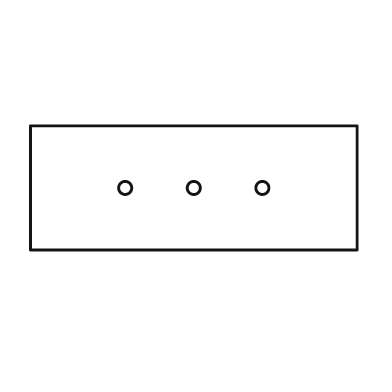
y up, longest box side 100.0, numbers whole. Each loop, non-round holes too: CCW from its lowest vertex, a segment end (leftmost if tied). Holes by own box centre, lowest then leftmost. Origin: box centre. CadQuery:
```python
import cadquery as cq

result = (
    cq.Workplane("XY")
    .moveTo(-50.0, -19.0)
    .lineTo(50.0, -19.0)
    .lineTo(50.0, 19.0)
    .lineTo(-50.0, 19.0)
    .close()
    .moveTo(-21.0, 0.0)
    .circle(2.0)
    .moveTo(0.0, 0.0)
    .circle(2.0)
    .moveTo(21.0, 0.0)
    .circle(2.0)
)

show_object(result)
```